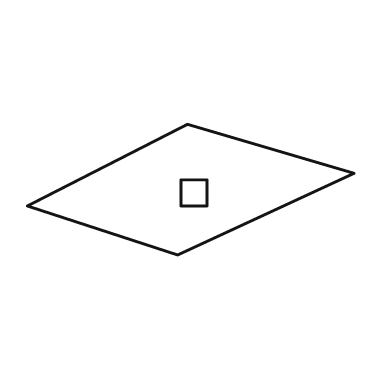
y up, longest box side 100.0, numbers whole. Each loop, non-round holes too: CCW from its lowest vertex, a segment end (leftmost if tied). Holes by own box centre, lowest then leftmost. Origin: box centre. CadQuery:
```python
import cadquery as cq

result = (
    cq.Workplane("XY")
    .moveTo(-4.0, -20.0)
    .lineTo(50.0, 5.0)
    .lineTo(-1.0, 20.0)
    .lineTo(-50.0, -5.0)
    .close()
    .moveTo(-3.0, -5.0)
    .lineTo(5.0, -5.0)
    .lineTo(5.0, 3.0)
    .lineTo(-3.0, 3.0)
    .close()
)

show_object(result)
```